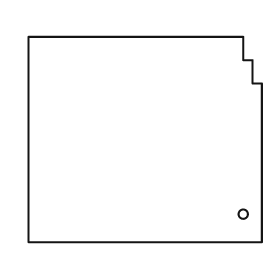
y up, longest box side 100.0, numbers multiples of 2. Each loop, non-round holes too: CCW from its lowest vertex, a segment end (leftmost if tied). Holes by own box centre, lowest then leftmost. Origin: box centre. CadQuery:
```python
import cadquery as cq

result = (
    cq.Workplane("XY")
    .moveTo(-50.0, -44.0)
    .lineTo(50.0, -44.0)
    .lineTo(50.0, 24.0)
    .lineTo(46.0, 24.0)
    .lineTo(46.0, 34.0)
    .lineTo(42.0, 34.0)
    .lineTo(42.0, 44.0)
    .lineTo(-50.0, 44.0)
    .close()
    .moveTo(42.0, -32.0)
    .circle(2.0)
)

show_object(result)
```